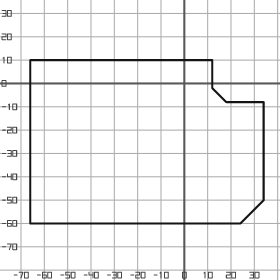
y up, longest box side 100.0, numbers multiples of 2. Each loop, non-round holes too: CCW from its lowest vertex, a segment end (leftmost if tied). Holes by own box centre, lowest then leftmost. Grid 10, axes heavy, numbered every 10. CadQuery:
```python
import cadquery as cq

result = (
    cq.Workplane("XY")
    .moveTo(-66.0, -60.0)
    .lineTo(24.0, -60.0)
    .lineTo(34.0, -50.0)
    .lineTo(34.0, -8.0)
    .lineTo(18.0, -8.0)
    .lineTo(12.0, -2.0)
    .lineTo(12.0, 10.0)
    .lineTo(-66.0, 10.0)
    .close()
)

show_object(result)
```